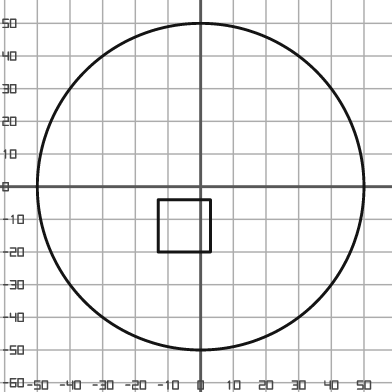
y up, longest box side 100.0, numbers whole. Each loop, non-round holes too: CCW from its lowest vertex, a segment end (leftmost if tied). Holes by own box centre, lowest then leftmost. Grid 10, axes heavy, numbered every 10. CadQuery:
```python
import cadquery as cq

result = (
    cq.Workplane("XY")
    .moveTo(0.0, 0.0)
    .circle(50.0)
    .moveTo(-13.0, -20.0)
    .lineTo(3.0, -20.0)
    .lineTo(3.0, -4.0)
    .lineTo(-13.0, -4.0)
    .close()
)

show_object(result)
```